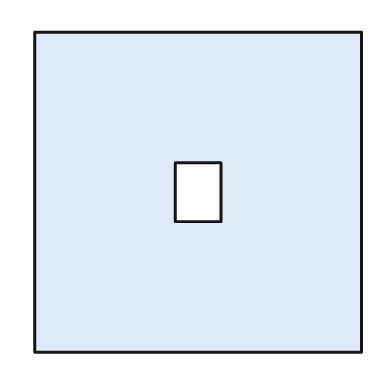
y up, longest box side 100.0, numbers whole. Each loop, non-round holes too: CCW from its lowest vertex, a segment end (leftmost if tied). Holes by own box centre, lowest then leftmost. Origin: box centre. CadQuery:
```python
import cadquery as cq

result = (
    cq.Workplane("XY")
    .moveTo(-50.0, -49.0)
    .lineTo(50.0, -49.0)
    .lineTo(50.0, 49.0)
    .lineTo(-50.0, 49.0)
    .close()
    .moveTo(-7.0, -9.0)
    .lineTo(7.0, -9.0)
    .lineTo(7.0, 9.0)
    .lineTo(-7.0, 9.0)
    .close()
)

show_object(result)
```